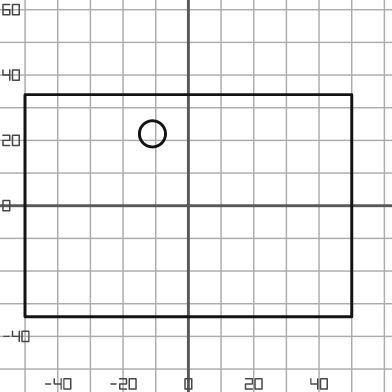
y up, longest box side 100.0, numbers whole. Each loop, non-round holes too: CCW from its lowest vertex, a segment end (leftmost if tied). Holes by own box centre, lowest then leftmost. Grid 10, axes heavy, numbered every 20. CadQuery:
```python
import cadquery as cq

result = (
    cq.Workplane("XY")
    .moveTo(-50.0, -34.0)
    .lineTo(50.0, -34.0)
    .lineTo(50.0, 34.0)
    .lineTo(-50.0, 34.0)
    .close()
    .moveTo(-11.0, 22.0)
    .circle(4.0)
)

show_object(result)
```